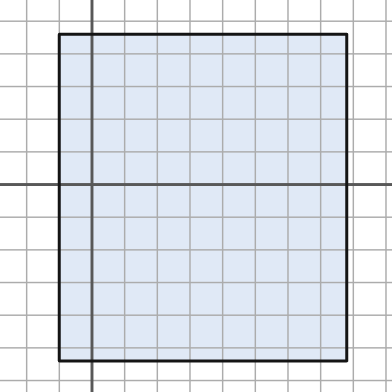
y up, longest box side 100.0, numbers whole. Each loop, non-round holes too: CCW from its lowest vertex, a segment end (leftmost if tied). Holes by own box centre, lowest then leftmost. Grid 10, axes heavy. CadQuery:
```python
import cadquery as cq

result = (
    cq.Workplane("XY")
    .moveTo(-10.0, -54.0)
    .lineTo(78.0, -54.0)
    .lineTo(78.0, 46.0)
    .lineTo(-10.0, 46.0)
    .close()
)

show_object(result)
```